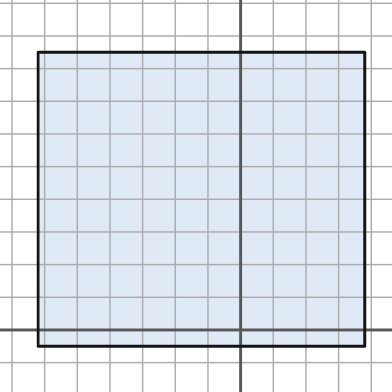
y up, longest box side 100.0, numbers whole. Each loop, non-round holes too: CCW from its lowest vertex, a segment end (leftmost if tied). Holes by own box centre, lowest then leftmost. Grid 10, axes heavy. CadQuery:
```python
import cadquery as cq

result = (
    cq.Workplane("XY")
    .moveTo(-62.0, -5.0)
    .lineTo(38.0, -5.0)
    .lineTo(38.0, 85.0)
    .lineTo(-62.0, 85.0)
    .close()
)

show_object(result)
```